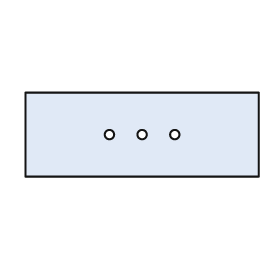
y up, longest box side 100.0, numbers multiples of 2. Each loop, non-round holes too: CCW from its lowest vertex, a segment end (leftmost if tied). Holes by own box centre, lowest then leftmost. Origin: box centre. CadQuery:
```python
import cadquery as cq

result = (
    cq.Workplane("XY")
    .moveTo(-50.0, -18.0)
    .lineTo(50.0, -18.0)
    .lineTo(50.0, 18.0)
    .lineTo(-50.0, 18.0)
    .close()
    .moveTo(-14.0, 0.0)
    .circle(2.0)
    .moveTo(0.0, 0.0)
    .circle(2.0)
    .moveTo(14.0, 0.0)
    .circle(2.0)
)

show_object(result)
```